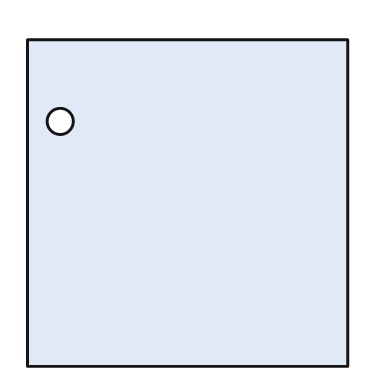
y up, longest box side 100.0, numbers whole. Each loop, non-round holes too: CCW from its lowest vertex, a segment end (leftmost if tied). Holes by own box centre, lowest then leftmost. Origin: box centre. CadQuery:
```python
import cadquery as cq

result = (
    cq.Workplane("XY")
    .moveTo(-49.0, -50.0)
    .lineTo(49.0, -50.0)
    .lineTo(49.0, 50.0)
    .lineTo(-49.0, 50.0)
    .close()
    .moveTo(-39.0, 25.0)
    .circle(4.0)
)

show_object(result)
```